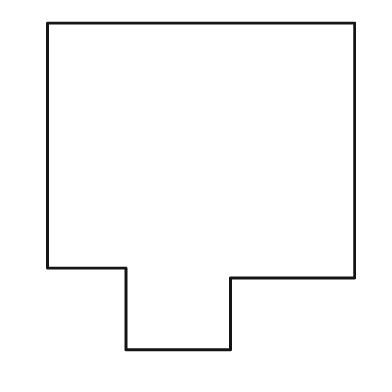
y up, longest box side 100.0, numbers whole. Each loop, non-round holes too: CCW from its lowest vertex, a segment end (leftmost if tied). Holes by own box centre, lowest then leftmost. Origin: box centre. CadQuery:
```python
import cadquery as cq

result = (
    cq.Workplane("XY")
    .moveTo(-23.0, -50.0)
    .lineTo(9.0, -50.0)
    .lineTo(9.0, -28.0)
    .lineTo(47.0, -28.0)
    .lineTo(47.0, 50.0)
    .lineTo(-47.0, 50.0)
    .lineTo(-47.0, -25.0)
    .lineTo(-23.0, -25.0)
    .close()
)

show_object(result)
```